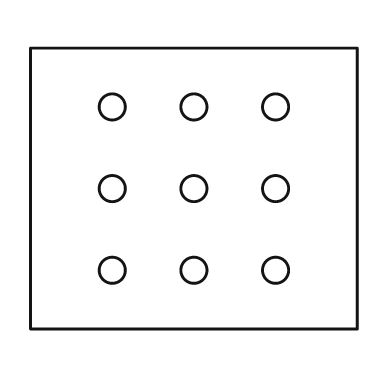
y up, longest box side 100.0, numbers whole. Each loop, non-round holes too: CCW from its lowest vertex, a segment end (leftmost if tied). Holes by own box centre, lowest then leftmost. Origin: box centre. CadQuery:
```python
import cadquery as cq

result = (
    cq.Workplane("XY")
    .moveTo(-50.0, -43.0)
    .lineTo(50.0, -43.0)
    .lineTo(50.0, 43.0)
    .lineTo(-50.0, 43.0)
    .close()
    .moveTo(-25.0, -25.0)
    .circle(4.0)
    .moveTo(0.0, -25.0)
    .circle(4.0)
    .moveTo(25.0, -25.0)
    .circle(4.0)
    .moveTo(-25.0, 0.0)
    .circle(4.0)
    .moveTo(0.0, 0.0)
    .circle(4.0)
    .moveTo(25.0, 0.0)
    .circle(4.0)
    .moveTo(-25.0, 25.0)
    .circle(4.0)
    .moveTo(0.0, 25.0)
    .circle(4.0)
    .moveTo(25.0, 25.0)
    .circle(4.0)
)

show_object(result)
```